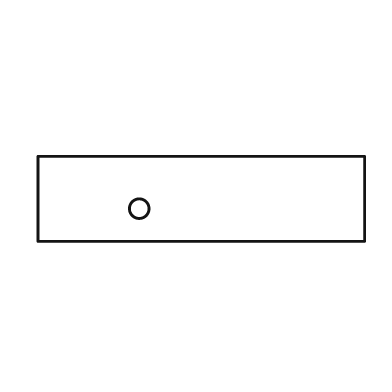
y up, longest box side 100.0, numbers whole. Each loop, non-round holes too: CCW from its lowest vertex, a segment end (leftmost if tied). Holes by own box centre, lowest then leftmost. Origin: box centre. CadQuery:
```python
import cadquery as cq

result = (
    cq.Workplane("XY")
    .moveTo(-50.0, -13.0)
    .lineTo(50.0, -13.0)
    .lineTo(50.0, 13.0)
    .lineTo(-50.0, 13.0)
    .close()
    .moveTo(-19.0, -3.0)
    .circle(3.0)
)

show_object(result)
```